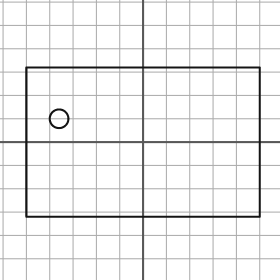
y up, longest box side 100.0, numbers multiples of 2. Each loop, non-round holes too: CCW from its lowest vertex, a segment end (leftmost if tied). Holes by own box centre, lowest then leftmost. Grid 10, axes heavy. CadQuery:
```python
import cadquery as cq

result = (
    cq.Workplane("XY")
    .moveTo(-50.0, -32.0)
    .lineTo(50.0, -32.0)
    .lineTo(50.0, 32.0)
    .lineTo(-50.0, 32.0)
    .close()
    .moveTo(-36.0, 10.0)
    .circle(4.0)
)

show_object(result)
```